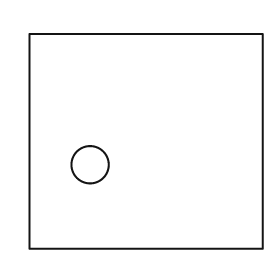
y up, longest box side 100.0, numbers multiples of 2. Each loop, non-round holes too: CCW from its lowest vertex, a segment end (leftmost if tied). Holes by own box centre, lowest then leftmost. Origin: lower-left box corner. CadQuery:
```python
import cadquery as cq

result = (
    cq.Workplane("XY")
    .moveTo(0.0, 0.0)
    .lineTo(100.0, 0.0)
    .lineTo(100.0, 92.0)
    .lineTo(0.0, 92.0)
    .close()
    .moveTo(26.0, 36.0)
    .circle(8.0)
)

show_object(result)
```